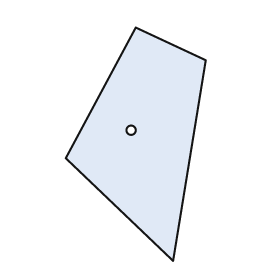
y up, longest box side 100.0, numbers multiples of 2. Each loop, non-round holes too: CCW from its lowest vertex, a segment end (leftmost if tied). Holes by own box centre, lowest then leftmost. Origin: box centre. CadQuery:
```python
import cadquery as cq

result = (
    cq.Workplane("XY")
    .moveTo(16.0, -50.0)
    .lineTo(30.0, 36.0)
    .lineTo(0.0, 50.0)
    .lineTo(-30.0, -6.0)
    .close()
    .moveTo(-2.0, 6.0)
    .circle(2.0)
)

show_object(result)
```